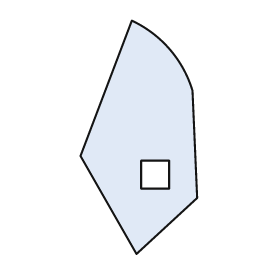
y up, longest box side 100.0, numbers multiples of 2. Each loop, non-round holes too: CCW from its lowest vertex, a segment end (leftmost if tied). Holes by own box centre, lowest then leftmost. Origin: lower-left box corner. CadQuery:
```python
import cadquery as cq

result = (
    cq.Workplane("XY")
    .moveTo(24.0, 0.0)
    .lineTo(50.0, 24.0)
    .lineTo(48.0, 70.0)
    .threePointArc((38.0, 88.0), (22.0, 100.0))
    .lineTo(0.0, 42.0)
    .close()
    .moveTo(26.0, 28.0)
    .lineTo(38.0, 28.0)
    .lineTo(38.0, 40.0)
    .lineTo(26.0, 40.0)
    .close()
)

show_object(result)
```